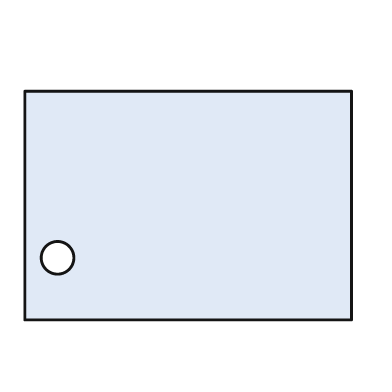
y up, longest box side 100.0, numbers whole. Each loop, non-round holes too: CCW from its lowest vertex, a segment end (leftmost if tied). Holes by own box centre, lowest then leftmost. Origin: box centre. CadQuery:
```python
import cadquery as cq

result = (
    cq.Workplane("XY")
    .moveTo(-50.0, -35.0)
    .lineTo(50.0, -35.0)
    .lineTo(50.0, 35.0)
    .lineTo(-50.0, 35.0)
    .close()
    .moveTo(-40.0, -16.0)
    .circle(5.0)
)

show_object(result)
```